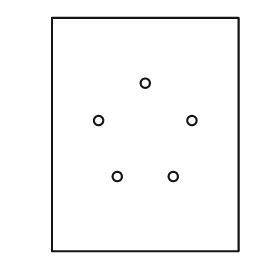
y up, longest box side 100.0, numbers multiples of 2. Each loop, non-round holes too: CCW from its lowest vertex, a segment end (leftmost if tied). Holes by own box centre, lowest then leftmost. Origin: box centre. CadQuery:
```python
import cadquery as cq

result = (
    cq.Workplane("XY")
    .moveTo(-40.0, -50.0)
    .lineTo(40.0, -50.0)
    .lineTo(40.0, 50.0)
    .lineTo(-40.0, 50.0)
    .close()
    .moveTo(-12.0, -18.0)
    .circle(2.0)
    .moveTo(12.0, -18.0)
    .circle(2.0)
    .moveTo(-20.0, 6.0)
    .circle(2.0)
    .moveTo(20.0, 6.0)
    .circle(2.0)
    .moveTo(0.0, 22.0)
    .circle(2.0)
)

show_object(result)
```